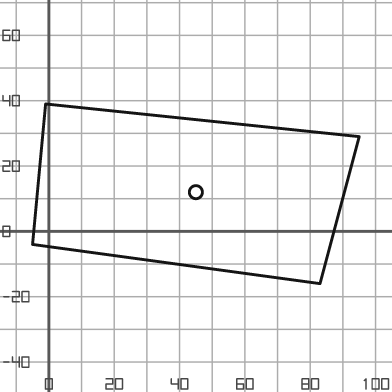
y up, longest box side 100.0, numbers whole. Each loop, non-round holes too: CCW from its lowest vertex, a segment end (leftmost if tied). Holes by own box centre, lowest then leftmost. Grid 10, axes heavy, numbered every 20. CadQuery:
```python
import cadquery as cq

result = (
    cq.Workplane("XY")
    .moveTo(83.0, -16.0)
    .lineTo(95.0, 29.0)
    .lineTo(-1.0, 39.0)
    .lineTo(-5.0, -4.0)
    .close()
    .moveTo(45.0, 12.0)
    .circle(2.0)
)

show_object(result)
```